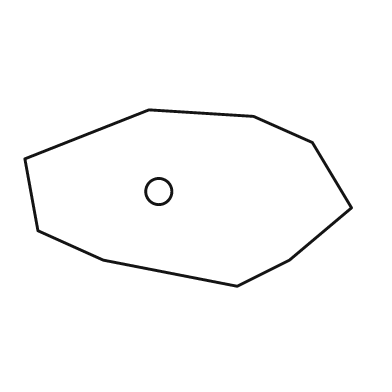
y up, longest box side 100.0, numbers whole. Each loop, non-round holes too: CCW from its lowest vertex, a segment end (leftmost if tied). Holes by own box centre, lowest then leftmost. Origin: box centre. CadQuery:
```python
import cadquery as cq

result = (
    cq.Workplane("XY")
    .moveTo(15.0, -27.0)
    .lineTo(31.0, -19.0)
    .lineTo(50.0, -3.0)
    .lineTo(38.0, 17.0)
    .lineTo(20.0, 25.0)
    .lineTo(-12.0, 27.0)
    .lineTo(-50.0, 12.0)
    .lineTo(-46.0, -10.0)
    .lineTo(-26.0, -19.0)
    .close()
    .moveTo(-9.0, 2.0)
    .circle(4.0)
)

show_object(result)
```